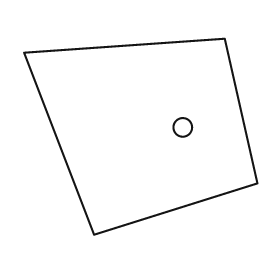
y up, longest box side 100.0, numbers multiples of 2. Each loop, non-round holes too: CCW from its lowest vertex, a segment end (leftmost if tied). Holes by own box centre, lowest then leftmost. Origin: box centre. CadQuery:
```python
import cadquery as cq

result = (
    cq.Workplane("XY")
    .moveTo(-20.0, -42.0)
    .lineTo(50.0, -20.0)
    .lineTo(36.0, 42.0)
    .lineTo(-50.0, 36.0)
    .close()
    .moveTo(18.0, 4.0)
    .circle(4.0)
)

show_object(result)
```